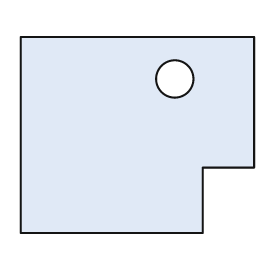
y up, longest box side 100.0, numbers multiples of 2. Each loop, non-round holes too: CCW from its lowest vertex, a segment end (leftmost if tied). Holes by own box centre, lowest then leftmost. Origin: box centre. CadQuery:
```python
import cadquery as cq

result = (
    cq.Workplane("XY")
    .moveTo(-50.0, -42.0)
    .lineTo(28.0, -42.0)
    .lineTo(28.0, -14.0)
    .lineTo(50.0, -14.0)
    .lineTo(50.0, 42.0)
    .lineTo(-50.0, 42.0)
    .close()
    .moveTo(16.0, 24.0)
    .circle(8.0)
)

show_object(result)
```